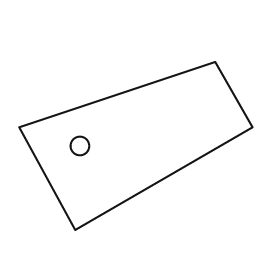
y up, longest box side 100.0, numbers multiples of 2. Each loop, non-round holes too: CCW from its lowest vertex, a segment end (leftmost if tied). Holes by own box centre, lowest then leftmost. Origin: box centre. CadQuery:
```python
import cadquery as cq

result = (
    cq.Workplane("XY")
    .moveTo(-26.0, -36.0)
    .lineTo(50.0, 8.0)
    .lineTo(34.0, 36.0)
    .lineTo(-50.0, 8.0)
    .close()
    .moveTo(-24.0, 0.0)
    .circle(4.0)
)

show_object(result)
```